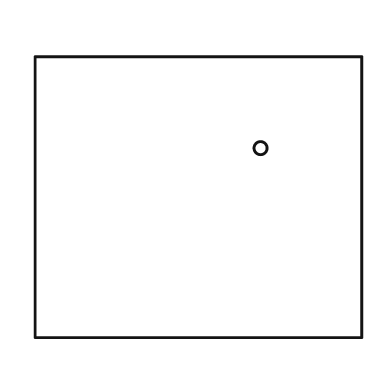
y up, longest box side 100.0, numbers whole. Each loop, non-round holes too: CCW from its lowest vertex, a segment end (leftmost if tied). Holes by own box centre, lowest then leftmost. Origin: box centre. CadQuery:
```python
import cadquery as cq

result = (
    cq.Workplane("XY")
    .moveTo(-50.0, -43.0)
    .lineTo(50.0, -43.0)
    .lineTo(50.0, 43.0)
    .lineTo(-50.0, 43.0)
    .close()
    .moveTo(19.0, 15.0)
    .circle(2.0)
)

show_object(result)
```